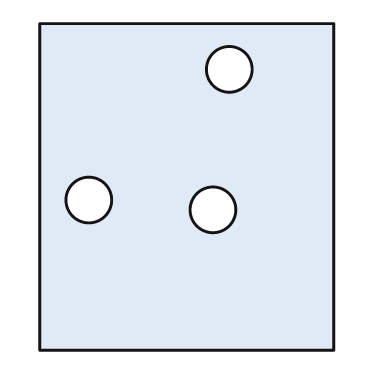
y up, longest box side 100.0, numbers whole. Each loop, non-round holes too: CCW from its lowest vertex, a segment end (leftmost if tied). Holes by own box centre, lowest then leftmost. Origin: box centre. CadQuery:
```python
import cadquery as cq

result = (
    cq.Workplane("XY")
    .moveTo(-45.0, -50.0)
    .lineTo(45.0, -50.0)
    .lineTo(45.0, 50.0)
    .lineTo(-45.0, 50.0)
    .close()
    .moveTo(8.0, -7.0)
    .circle(7.0)
    .moveTo(-30.0, -4.0)
    .circle(7.0)
    .moveTo(13.0, 36.0)
    .circle(7.0)
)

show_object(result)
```